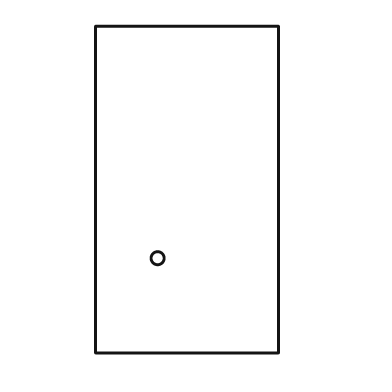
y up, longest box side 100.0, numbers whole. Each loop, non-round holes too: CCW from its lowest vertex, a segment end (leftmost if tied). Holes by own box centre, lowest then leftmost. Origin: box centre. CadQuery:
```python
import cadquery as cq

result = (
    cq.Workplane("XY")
    .moveTo(-28.0, -50.0)
    .lineTo(28.0, -50.0)
    .lineTo(28.0, 50.0)
    .lineTo(-28.0, 50.0)
    .close()
    .moveTo(-9.0, -21.0)
    .circle(2.0)
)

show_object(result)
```